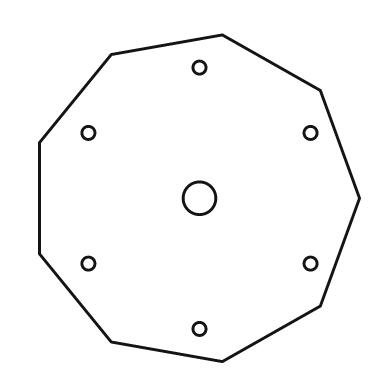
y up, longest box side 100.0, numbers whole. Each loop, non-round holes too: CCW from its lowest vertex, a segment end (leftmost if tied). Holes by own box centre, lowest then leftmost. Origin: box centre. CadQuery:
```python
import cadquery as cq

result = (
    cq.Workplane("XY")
    .moveTo(7.0, -50.0)
    .lineTo(37.0, -33.0)
    .lineTo(49.0, 0.0)
    .lineTo(37.0, 33.0)
    .lineTo(7.0, 50.0)
    .lineTo(-27.0, 44.0)
    .lineTo(-49.0, 17.0)
    .lineTo(-49.0, -17.0)
    .lineTo(-27.0, -44.0)
    .close()
    .moveTo(0.0, -40.0)
    .circle(2.0)
    .moveTo(-34.0, -20.0)
    .circle(2.0)
    .moveTo(34.0, -20.0)
    .circle(2.0)
    .moveTo(0.0, 0.0)
    .circle(5.0)
    .moveTo(-34.0, 20.0)
    .circle(2.0)
    .moveTo(34.0, 20.0)
    .circle(2.0)
    .moveTo(0.0, 40.0)
    .circle(2.0)
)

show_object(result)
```